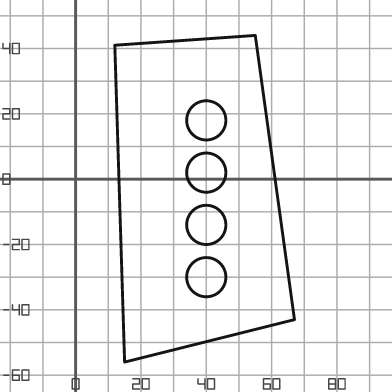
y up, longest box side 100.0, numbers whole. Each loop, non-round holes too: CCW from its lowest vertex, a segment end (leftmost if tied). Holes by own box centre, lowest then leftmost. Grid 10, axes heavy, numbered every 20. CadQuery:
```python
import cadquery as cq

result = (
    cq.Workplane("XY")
    .moveTo(15.0, -56.0)
    .lineTo(67.0, -43.0)
    .lineTo(55.0, 44.0)
    .lineTo(12.0, 41.0)
    .close()
    .moveTo(40.0, -30.0)
    .circle(6.0)
    .moveTo(40.0, -14.0)
    .circle(6.0)
    .moveTo(40.0, 2.0)
    .circle(6.0)
    .moveTo(40.0, 18.0)
    .circle(6.0)
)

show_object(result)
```